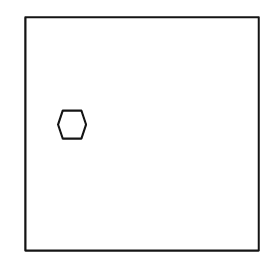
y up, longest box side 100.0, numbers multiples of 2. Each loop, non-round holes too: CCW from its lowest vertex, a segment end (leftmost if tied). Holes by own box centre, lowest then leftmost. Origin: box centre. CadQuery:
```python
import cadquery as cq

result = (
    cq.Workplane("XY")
    .moveTo(-50.0, -50.0)
    .lineTo(50.0, -50.0)
    .lineTo(50.0, 50.0)
    .lineTo(-50.0, 50.0)
    .close()
    .moveTo(-34.0, -2.0)
    .lineTo(-26.0, -2.0)
    .lineTo(-24.0, 4.0)
    .lineTo(-26.0, 10.0)
    .lineTo(-34.0, 10.0)
    .lineTo(-36.0, 4.0)
    .close()
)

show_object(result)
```